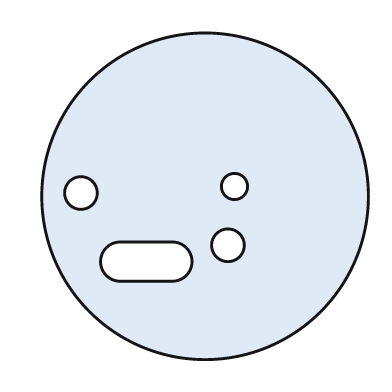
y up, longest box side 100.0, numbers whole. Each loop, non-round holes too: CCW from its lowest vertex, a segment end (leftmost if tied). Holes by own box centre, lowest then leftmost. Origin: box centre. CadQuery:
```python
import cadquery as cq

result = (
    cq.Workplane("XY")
    .moveTo(0.0, 0.0)
    .circle(50.0)
    .moveTo(-26.0, -26.0)
    .lineTo(-10.0, -26.0)
    .threePointArc((-4.0, -20.0), (-10.0, -14.0))
    .lineTo(-26.0, -14.0)
    .threePointArc((-32.0, -20.0), (-26.0, -26.0))
    .close()
    .moveTo(7.0, -15.0)
    .circle(5.0)
    .moveTo(-38.0, 1.0)
    .circle(5.0)
    .moveTo(9.0, 3.0)
    .circle(4.0)
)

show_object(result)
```